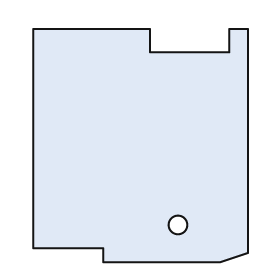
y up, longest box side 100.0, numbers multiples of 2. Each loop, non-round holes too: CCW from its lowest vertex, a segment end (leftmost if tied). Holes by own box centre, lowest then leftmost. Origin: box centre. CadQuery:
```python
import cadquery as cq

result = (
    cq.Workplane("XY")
    .moveTo(-16.0, -50.0)
    .lineTo(34.0, -50.0)
    .lineTo(46.0, -46.0)
    .lineTo(46.0, 50.0)
    .lineTo(38.0, 50.0)
    .lineTo(38.0, 40.0)
    .lineTo(4.0, 40.0)
    .lineTo(4.0, 50.0)
    .lineTo(-46.0, 50.0)
    .lineTo(-46.0, -44.0)
    .lineTo(-16.0, -44.0)
    .close()
    .moveTo(16.0, -34.0)
    .circle(4.0)
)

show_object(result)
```